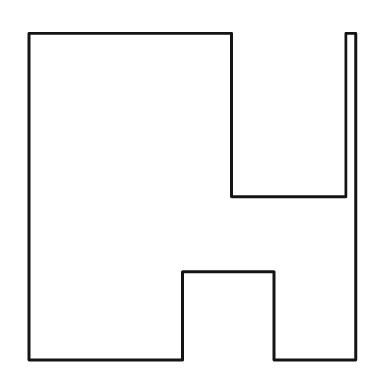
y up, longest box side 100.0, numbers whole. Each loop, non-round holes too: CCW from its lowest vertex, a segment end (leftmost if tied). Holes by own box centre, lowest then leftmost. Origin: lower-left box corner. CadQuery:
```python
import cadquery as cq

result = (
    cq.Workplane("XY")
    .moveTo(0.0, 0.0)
    .lineTo(47.0, 0.0)
    .lineTo(47.0, 27.0)
    .lineTo(75.0, 27.0)
    .lineTo(75.0, 0.0)
    .lineTo(100.0, 0.0)
    .lineTo(100.0, 100.0)
    .lineTo(97.0, 100.0)
    .lineTo(97.0, 50.0)
    .lineTo(62.0, 50.0)
    .lineTo(62.0, 100.0)
    .lineTo(0.0, 100.0)
    .close()
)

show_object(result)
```